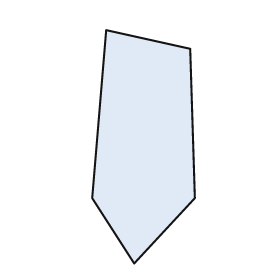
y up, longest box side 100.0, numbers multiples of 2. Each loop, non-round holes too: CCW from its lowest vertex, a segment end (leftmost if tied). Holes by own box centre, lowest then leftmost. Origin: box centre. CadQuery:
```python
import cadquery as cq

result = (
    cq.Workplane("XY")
    .moveTo(-4.0, -50.0)
    .lineTo(22.0, -22.0)
    .lineTo(20.0, 42.0)
    .lineTo(-16.0, 50.0)
    .lineTo(-22.0, -22.0)
    .close()
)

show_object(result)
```